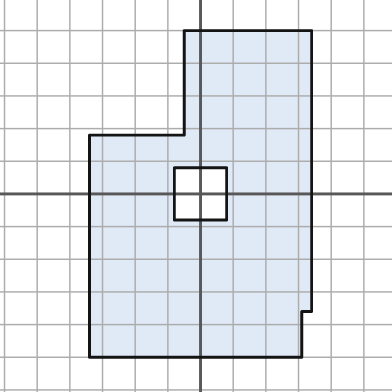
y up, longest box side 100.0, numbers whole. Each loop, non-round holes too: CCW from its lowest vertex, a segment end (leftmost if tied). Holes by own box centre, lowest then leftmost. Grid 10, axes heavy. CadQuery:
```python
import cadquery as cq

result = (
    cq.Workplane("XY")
    .moveTo(-34.0, -50.0)
    .lineTo(31.0, -50.0)
    .lineTo(31.0, -36.0)
    .lineTo(34.0, -36.0)
    .lineTo(34.0, 50.0)
    .lineTo(-5.0, 50.0)
    .lineTo(-5.0, 18.0)
    .lineTo(-34.0, 18.0)
    .close()
    .moveTo(-8.0, -8.0)
    .lineTo(8.0, -8.0)
    .lineTo(8.0, 8.0)
    .lineTo(-8.0, 8.0)
    .close()
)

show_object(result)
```